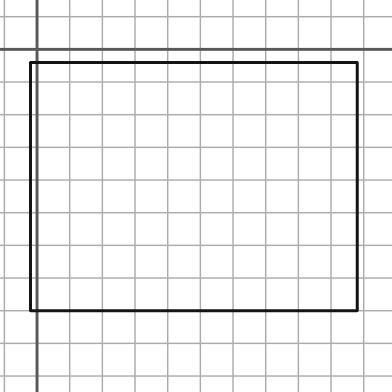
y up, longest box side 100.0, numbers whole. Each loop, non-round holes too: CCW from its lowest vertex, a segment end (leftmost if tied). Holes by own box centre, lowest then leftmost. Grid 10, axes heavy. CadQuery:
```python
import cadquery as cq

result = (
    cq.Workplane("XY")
    .moveTo(-2.0, -80.0)
    .lineTo(98.0, -80.0)
    .lineTo(98.0, -4.0)
    .lineTo(-2.0, -4.0)
    .close()
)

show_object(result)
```